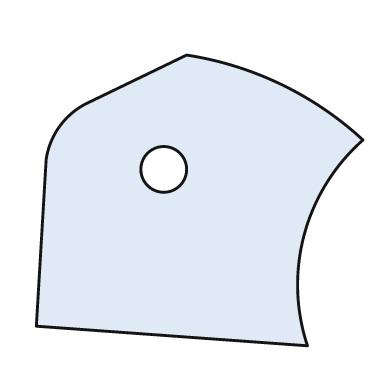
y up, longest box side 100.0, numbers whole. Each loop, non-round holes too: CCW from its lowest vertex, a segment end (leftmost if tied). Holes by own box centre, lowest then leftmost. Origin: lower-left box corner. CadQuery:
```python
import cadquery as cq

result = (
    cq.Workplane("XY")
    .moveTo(83.0, 0.0)
    .threePointArc((82.0, 34.0), (100.0, 63.0))
    .threePointArc((75.0, 80.0), (46.0, 89.0))
    .lineTo(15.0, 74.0)
    .threePointArc((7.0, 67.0), (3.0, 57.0))
    .lineTo(0.0, 6.0)
    .close()
    .moveTo(39.0, 54.0)
    .circle(7.0)
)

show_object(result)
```